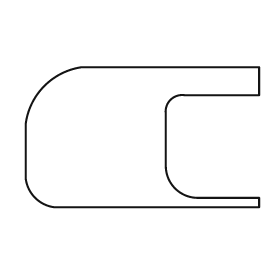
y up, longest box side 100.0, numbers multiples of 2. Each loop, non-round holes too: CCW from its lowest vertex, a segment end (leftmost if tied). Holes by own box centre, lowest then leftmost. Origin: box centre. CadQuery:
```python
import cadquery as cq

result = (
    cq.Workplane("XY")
    .moveTo(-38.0, -30.0)
    .lineTo(50.0, -30.0)
    .lineTo(50.0, -26.0)
    .lineTo(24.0, -26.0)
    .threePointArc((14.0, -22.0), (10.0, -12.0))
    .lineTo(10.0, 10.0)
    .threePointArc((12.0, 16.0), (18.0, 18.0))
    .lineTo(50.0, 18.0)
    .lineTo(50.0, 30.0)
    .lineTo(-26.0, 30.0)
    .threePointArc((-42.0, 22.0), (-50.0, 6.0))
    .lineTo(-50.0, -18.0)
    .threePointArc((-46.0, -26.0), (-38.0, -30.0))
    .close()
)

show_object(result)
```